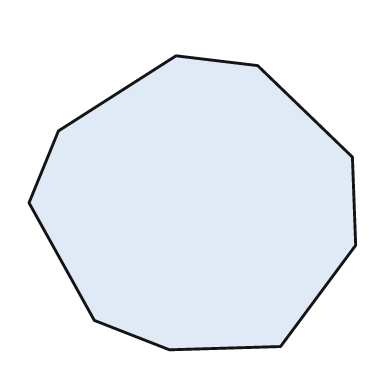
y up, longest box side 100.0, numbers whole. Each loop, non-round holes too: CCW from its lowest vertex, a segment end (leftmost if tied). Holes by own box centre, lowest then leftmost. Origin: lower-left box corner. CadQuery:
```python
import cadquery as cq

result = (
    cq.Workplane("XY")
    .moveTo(43.0, 0.0)
    .lineTo(77.0, 1.0)
    .lineTo(100.0, 32.0)
    .lineTo(99.0, 59.0)
    .lineTo(70.0, 87.0)
    .lineTo(45.0, 90.0)
    .lineTo(9.0, 67.0)
    .lineTo(0.0, 45.0)
    .lineTo(20.0, 9.0)
    .close()
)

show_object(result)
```